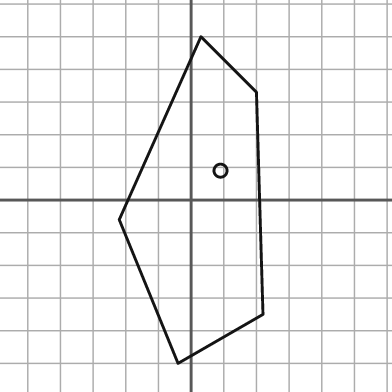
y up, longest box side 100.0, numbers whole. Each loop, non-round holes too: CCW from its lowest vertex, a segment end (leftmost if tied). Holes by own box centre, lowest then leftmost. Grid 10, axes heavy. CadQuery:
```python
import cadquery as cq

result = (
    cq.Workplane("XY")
    .moveTo(-4.0, -50.0)
    .lineTo(22.0, -35.0)
    .lineTo(20.0, 33.0)
    .lineTo(3.0, 50.0)
    .lineTo(-22.0, -6.0)
    .close()
    .moveTo(9.0, 9.0)
    .circle(2.0)
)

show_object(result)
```